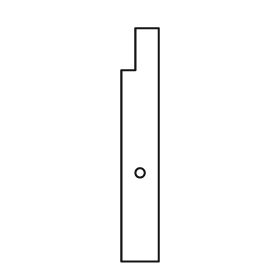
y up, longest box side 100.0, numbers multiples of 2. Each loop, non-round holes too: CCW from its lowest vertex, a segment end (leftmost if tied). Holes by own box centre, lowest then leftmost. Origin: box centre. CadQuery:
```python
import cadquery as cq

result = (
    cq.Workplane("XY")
    .moveTo(-8.0, -50.0)
    .lineTo(8.0, -50.0)
    .lineTo(8.0, 50.0)
    .lineTo(-2.0, 50.0)
    .lineTo(-2.0, 32.0)
    .lineTo(-8.0, 32.0)
    .close()
    .moveTo(0.0, -12.0)
    .circle(2.0)
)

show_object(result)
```